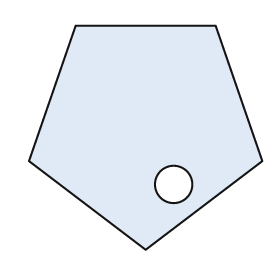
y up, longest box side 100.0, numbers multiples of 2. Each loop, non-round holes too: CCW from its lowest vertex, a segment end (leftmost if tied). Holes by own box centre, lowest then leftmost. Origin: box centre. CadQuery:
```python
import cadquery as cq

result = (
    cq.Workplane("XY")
    .moveTo(0.0, -48.0)
    .lineTo(50.0, -10.0)
    .lineTo(30.0, 48.0)
    .lineTo(-30.0, 48.0)
    .lineTo(-50.0, -10.0)
    .close()
    .moveTo(12.0, -20.0)
    .circle(8.0)
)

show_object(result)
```